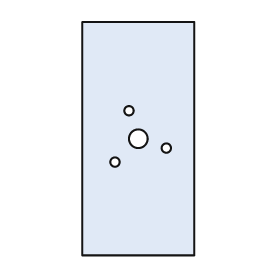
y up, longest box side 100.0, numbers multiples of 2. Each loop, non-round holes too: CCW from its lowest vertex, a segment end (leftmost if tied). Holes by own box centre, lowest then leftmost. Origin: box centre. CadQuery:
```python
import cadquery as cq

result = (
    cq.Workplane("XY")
    .moveTo(-24.0, -50.0)
    .lineTo(24.0, -50.0)
    .lineTo(24.0, 50.0)
    .lineTo(-24.0, 50.0)
    .close()
    .moveTo(-10.0, -10.0)
    .circle(2.0)
    .moveTo(12.0, -4.0)
    .circle(2.0)
    .moveTo(0.0, 0.0)
    .circle(4.0)
    .moveTo(-4.0, 12.0)
    .circle(2.0)
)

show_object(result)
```